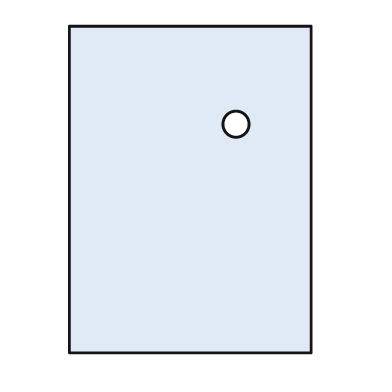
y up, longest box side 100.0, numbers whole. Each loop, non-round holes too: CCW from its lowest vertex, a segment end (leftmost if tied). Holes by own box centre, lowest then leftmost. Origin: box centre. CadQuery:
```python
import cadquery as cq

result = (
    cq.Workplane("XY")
    .moveTo(-37.0, -50.0)
    .lineTo(37.0, -50.0)
    .lineTo(37.0, 50.0)
    .lineTo(-37.0, 50.0)
    .close()
    .moveTo(14.0, 20.0)
    .circle(4.0)
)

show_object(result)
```